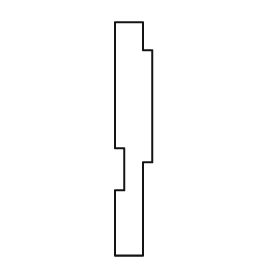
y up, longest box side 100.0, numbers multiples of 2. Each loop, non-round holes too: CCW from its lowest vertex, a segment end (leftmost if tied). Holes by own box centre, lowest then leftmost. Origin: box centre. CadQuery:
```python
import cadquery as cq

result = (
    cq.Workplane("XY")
    .moveTo(-8.0, -50.0)
    .lineTo(4.0, -50.0)
    .lineTo(4.0, -10.0)
    .lineTo(8.0, -10.0)
    .lineTo(8.0, 38.0)
    .lineTo(4.0, 38.0)
    .lineTo(4.0, 50.0)
    .lineTo(-8.0, 50.0)
    .lineTo(-8.0, -4.0)
    .lineTo(-4.0, -4.0)
    .lineTo(-4.0, -22.0)
    .lineTo(-8.0, -22.0)
    .close()
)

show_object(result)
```